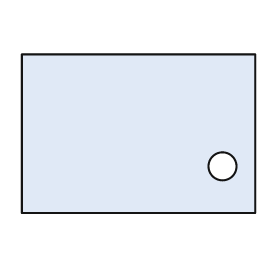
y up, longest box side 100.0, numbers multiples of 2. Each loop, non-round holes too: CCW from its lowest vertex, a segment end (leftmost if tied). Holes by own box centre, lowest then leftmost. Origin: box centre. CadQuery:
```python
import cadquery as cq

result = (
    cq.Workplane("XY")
    .moveTo(-50.0, -34.0)
    .lineTo(50.0, -34.0)
    .lineTo(50.0, 34.0)
    .lineTo(-50.0, 34.0)
    .close()
    .moveTo(36.0, -14.0)
    .circle(6.0)
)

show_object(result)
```